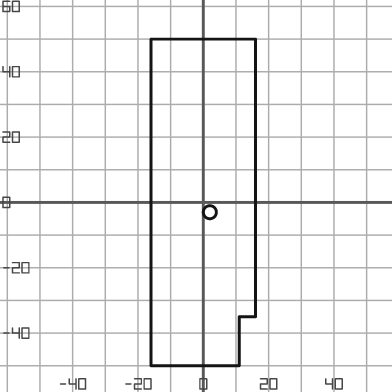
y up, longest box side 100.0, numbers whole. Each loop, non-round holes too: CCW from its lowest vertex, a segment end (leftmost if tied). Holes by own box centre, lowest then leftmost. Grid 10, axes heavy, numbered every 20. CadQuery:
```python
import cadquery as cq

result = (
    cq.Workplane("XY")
    .moveTo(-16.0, -50.0)
    .lineTo(11.0, -50.0)
    .lineTo(11.0, -35.0)
    .lineTo(16.0, -35.0)
    .lineTo(16.0, 50.0)
    .lineTo(-16.0, 50.0)
    .close()
    .moveTo(2.0, -3.0)
    .circle(2.0)
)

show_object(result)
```